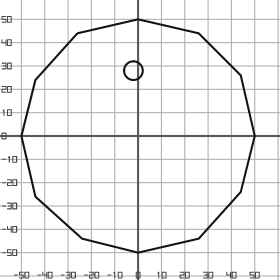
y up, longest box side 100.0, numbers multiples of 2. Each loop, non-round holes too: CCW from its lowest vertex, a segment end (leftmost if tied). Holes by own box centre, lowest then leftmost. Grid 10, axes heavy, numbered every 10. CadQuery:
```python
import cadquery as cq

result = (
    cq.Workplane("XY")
    .moveTo(0.0, -50.0)
    .lineTo(26.0, -44.0)
    .lineTo(44.0, -24.0)
    .lineTo(50.0, 0.0)
    .lineTo(44.0, 26.0)
    .lineTo(26.0, 44.0)
    .lineTo(0.0, 50.0)
    .lineTo(-26.0, 44.0)
    .lineTo(-44.0, 24.0)
    .lineTo(-50.0, 0.0)
    .lineTo(-44.0, -26.0)
    .lineTo(-24.0, -44.0)
    .close()
    .moveTo(-2.0, 28.0)
    .circle(4.0)
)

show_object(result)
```